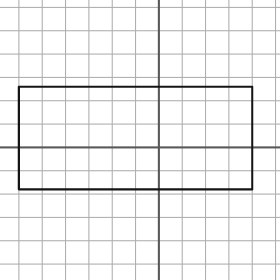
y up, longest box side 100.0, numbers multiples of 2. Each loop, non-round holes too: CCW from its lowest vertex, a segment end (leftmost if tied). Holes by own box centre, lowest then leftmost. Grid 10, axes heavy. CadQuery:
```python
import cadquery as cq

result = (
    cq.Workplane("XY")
    .moveTo(-60.0, -18.0)
    .lineTo(40.0, -18.0)
    .lineTo(40.0, 26.0)
    .lineTo(-60.0, 26.0)
    .close()
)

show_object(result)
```